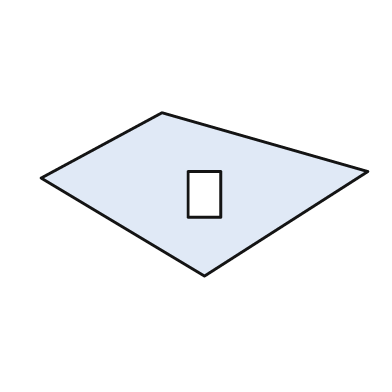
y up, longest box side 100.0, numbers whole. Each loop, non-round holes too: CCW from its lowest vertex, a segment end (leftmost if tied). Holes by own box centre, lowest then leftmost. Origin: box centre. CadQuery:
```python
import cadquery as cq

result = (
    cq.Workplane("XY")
    .moveTo(0.0, -25.0)
    .lineTo(50.0, 7.0)
    .lineTo(-13.0, 25.0)
    .lineTo(-50.0, 5.0)
    .close()
    .moveTo(-5.0, -7.0)
    .lineTo(5.0, -7.0)
    .lineTo(5.0, 7.0)
    .lineTo(-5.0, 7.0)
    .close()
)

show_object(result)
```